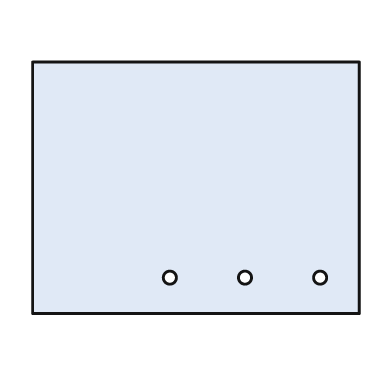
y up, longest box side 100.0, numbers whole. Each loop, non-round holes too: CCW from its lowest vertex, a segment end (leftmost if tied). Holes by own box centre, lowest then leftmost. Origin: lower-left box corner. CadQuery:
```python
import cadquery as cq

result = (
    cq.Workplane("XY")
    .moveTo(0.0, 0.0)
    .lineTo(100.0, 0.0)
    .lineTo(100.0, 77.0)
    .lineTo(0.0, 77.0)
    .close()
    .moveTo(42.0, 11.0)
    .circle(2.0)
    .moveTo(65.0, 11.0)
    .circle(2.0)
    .moveTo(88.0, 11.0)
    .circle(2.0)
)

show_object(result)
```